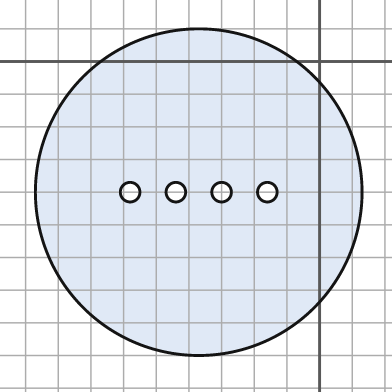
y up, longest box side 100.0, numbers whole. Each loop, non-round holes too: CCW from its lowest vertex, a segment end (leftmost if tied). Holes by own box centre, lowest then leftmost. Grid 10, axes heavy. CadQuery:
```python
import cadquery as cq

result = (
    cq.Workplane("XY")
    .moveTo(-37.0, -40.0)
    .circle(50.0)
    .moveTo(-58.0, -40.0)
    .circle(3.0)
    .moveTo(-44.0, -40.0)
    .circle(3.0)
    .moveTo(-30.0, -40.0)
    .circle(3.0)
    .moveTo(-16.0, -40.0)
    .circle(3.0)
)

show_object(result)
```